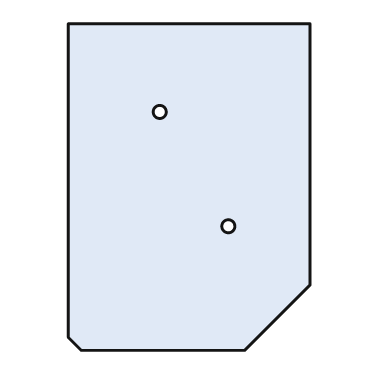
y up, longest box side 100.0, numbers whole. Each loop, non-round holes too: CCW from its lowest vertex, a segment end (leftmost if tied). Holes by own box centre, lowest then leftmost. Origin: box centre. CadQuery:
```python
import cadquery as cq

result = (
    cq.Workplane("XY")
    .moveTo(-33.0, -50.0)
    .lineTo(17.0, -50.0)
    .lineTo(37.0, -30.0)
    .lineTo(37.0, 50.0)
    .lineTo(-37.0, 50.0)
    .lineTo(-37.0, -46.0)
    .close()
    .moveTo(12.0, -12.0)
    .circle(2.0)
    .moveTo(-9.0, 23.0)
    .circle(2.0)
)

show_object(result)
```